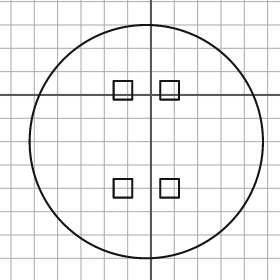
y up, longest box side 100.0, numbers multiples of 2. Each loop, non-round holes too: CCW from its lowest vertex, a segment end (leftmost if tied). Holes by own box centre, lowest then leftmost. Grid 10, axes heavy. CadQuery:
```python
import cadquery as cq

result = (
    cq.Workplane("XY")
    .moveTo(-2.0, -20.0)
    .circle(50.0)
    .moveTo(-16.0, -44.0)
    .lineTo(-8.0, -44.0)
    .lineTo(-8.0, -36.0)
    .lineTo(-16.0, -36.0)
    .close()
    .moveTo(4.0, -44.0)
    .lineTo(12.0, -44.0)
    .lineTo(12.0, -36.0)
    .lineTo(4.0, -36.0)
    .close()
    .moveTo(-16.0, -2.0)
    .lineTo(-8.0, -2.0)
    .lineTo(-8.0, 6.0)
    .lineTo(-16.0, 6.0)
    .close()
    .moveTo(4.0, -2.0)
    .lineTo(12.0, -2.0)
    .lineTo(12.0, 6.0)
    .lineTo(4.0, 6.0)
    .close()
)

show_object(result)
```